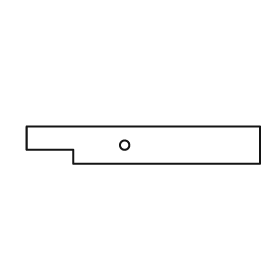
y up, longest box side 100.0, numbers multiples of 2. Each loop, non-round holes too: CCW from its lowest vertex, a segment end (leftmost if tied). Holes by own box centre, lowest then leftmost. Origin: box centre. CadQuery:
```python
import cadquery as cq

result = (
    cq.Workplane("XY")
    .moveTo(-30.0, -8.0)
    .lineTo(50.0, -8.0)
    .lineTo(50.0, 8.0)
    .lineTo(-50.0, 8.0)
    .lineTo(-50.0, -2.0)
    .lineTo(-30.0, -2.0)
    .close()
    .moveTo(-8.0, 0.0)
    .circle(2.0)
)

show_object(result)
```